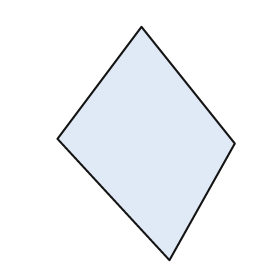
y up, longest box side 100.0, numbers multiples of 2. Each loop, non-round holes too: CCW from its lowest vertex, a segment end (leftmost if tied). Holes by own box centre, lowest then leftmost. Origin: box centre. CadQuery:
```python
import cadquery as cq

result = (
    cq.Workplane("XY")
    .moveTo(10.0, -50.0)
    .lineTo(38.0, 0.0)
    .lineTo(-2.0, 50.0)
    .lineTo(-38.0, 2.0)
    .close()
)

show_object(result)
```